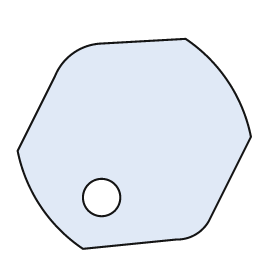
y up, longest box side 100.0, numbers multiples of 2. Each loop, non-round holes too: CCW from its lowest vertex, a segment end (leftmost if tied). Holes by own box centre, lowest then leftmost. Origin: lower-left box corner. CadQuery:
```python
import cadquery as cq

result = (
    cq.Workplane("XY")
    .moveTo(28.0, 0.0)
    .lineTo(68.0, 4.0)
    .threePointArc((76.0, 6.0), (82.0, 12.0))
    .lineTo(100.0, 48.0)
    .threePointArc((90.0, 72.0), (72.0, 90.0))
    .lineTo(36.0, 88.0)
    .threePointArc((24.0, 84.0), (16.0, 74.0))
    .lineTo(0.0, 42.0)
    .threePointArc((10.0, 18.0), (28.0, 0.0))
    .close()
    .moveTo(36.0, 22.0)
    .circle(8.0)
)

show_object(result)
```